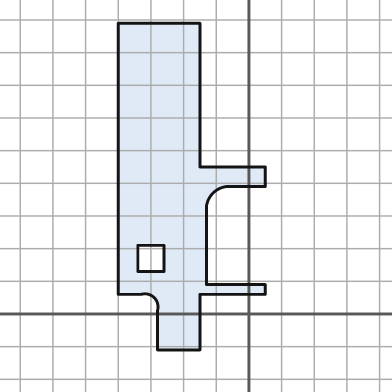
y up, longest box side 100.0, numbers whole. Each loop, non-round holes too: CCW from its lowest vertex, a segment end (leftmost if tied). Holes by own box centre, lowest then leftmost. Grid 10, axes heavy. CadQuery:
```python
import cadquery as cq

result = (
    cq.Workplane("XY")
    .moveTo(-28.0, -11.0)
    .lineTo(-15.0, -11.0)
    .lineTo(-15.0, 6.0)
    .lineTo(5.0, 6.0)
    .lineTo(5.0, 9.0)
    .lineTo(-13.0, 9.0)
    .lineTo(-13.0, 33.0)
    .threePointArc((-11.0, 37.0), (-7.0, 39.0))
    .lineTo(5.0, 39.0)
    .lineTo(5.0, 45.0)
    .lineTo(-15.0, 45.0)
    .lineTo(-15.0, 89.0)
    .lineTo(-40.0, 89.0)
    .lineTo(-40.0, 6.0)
    .lineTo(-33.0, 6.0)
    .threePointArc((-29.0, 5.0), (-28.0, 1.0))
    .close()
    .moveTo(-34.0, 13.0)
    .lineTo(-26.0, 13.0)
    .lineTo(-26.0, 21.0)
    .lineTo(-34.0, 21.0)
    .close()
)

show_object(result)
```